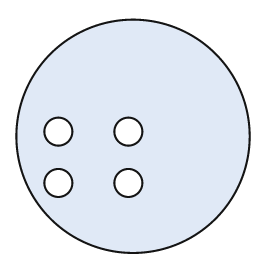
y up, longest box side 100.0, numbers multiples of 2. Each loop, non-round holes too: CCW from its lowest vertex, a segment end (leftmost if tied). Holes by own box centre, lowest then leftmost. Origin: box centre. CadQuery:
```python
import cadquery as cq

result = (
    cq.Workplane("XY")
    .moveTo(0.0, 0.0)
    .circle(50.0)
    .moveTo(-32.0, -20.0)
    .circle(6.0)
    .moveTo(-2.0, -20.0)
    .circle(6.0)
    .moveTo(-32.0, 2.0)
    .circle(6.0)
    .moveTo(-2.0, 2.0)
    .circle(6.0)
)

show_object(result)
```